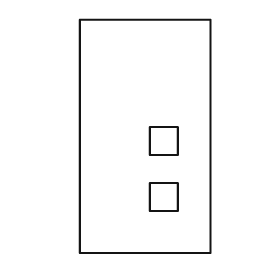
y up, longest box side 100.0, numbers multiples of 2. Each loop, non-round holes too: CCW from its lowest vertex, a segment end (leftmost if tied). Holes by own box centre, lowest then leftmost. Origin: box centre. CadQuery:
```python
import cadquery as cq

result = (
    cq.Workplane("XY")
    .moveTo(-28.0, -50.0)
    .lineTo(28.0, -50.0)
    .lineTo(28.0, 50.0)
    .lineTo(-28.0, 50.0)
    .close()
    .moveTo(2.0, -32.0)
    .lineTo(14.0, -32.0)
    .lineTo(14.0, -20.0)
    .lineTo(2.0, -20.0)
    .close()
    .moveTo(2.0, -8.0)
    .lineTo(14.0, -8.0)
    .lineTo(14.0, 4.0)
    .lineTo(2.0, 4.0)
    .close()
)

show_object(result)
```